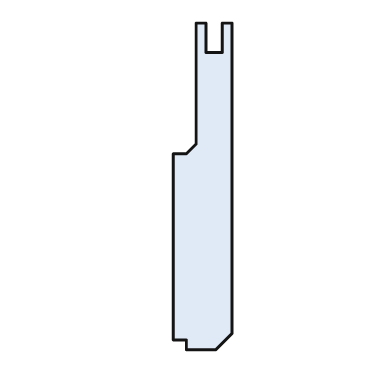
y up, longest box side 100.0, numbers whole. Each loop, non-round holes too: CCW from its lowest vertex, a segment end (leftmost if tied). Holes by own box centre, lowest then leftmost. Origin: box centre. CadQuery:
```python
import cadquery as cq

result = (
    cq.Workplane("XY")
    .moveTo(-5.0, -50.0)
    .lineTo(4.0, -50.0)
    .lineTo(9.0, -45.0)
    .lineTo(9.0, 50.0)
    .lineTo(6.0, 50.0)
    .lineTo(6.0, 41.0)
    .lineTo(1.0, 41.0)
    .lineTo(1.0, 50.0)
    .lineTo(-2.0, 50.0)
    .lineTo(-2.0, 13.0)
    .lineTo(-5.0, 10.0)
    .lineTo(-9.0, 10.0)
    .lineTo(-9.0, -47.0)
    .lineTo(-5.0, -47.0)
    .close()
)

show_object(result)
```